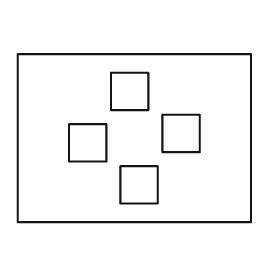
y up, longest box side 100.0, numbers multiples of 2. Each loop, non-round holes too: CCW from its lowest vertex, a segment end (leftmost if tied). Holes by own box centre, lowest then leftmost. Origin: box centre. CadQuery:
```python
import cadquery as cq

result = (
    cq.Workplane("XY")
    .moveTo(-50.0, -36.0)
    .lineTo(50.0, -36.0)
    .lineTo(50.0, 36.0)
    .lineTo(-50.0, 36.0)
    .close()
    .moveTo(-6.0, -28.0)
    .lineTo(10.0, -28.0)
    .lineTo(10.0, -12.0)
    .lineTo(-6.0, -12.0)
    .close()
    .moveTo(-28.0, -10.0)
    .lineTo(-12.0, -10.0)
    .lineTo(-12.0, 6.0)
    .lineTo(-28.0, 6.0)
    .close()
    .moveTo(12.0, -6.0)
    .lineTo(28.0, -6.0)
    .lineTo(28.0, 10.0)
    .lineTo(12.0, 10.0)
    .close()
    .moveTo(-10.0, 12.0)
    .lineTo(6.0, 12.0)
    .lineTo(6.0, 28.0)
    .lineTo(-10.0, 28.0)
    .close()
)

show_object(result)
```